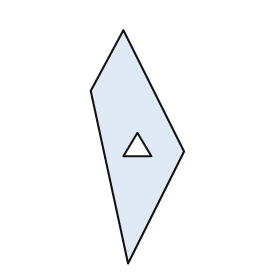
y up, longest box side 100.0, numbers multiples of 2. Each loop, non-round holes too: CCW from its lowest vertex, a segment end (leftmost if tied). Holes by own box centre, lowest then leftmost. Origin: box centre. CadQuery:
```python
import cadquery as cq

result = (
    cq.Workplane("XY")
    .moveTo(-4.0, -50.0)
    .lineTo(20.0, -2.0)
    .lineTo(-6.0, 50.0)
    .lineTo(-20.0, 24.0)
    .close()
    .moveTo(-6.0, -4.0)
    .lineTo(6.0, -4.0)
    .lineTo(0.0, 6.0)
    .close()
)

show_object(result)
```